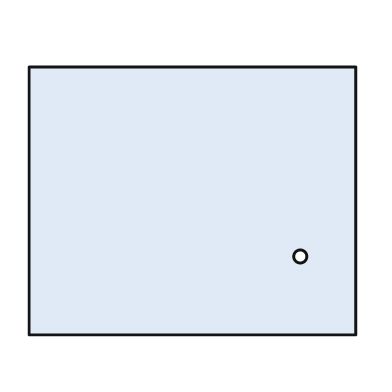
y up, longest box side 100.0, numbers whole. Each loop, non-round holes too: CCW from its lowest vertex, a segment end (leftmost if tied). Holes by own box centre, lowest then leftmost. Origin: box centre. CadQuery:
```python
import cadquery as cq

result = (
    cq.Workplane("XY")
    .moveTo(-50.0, -41.0)
    .lineTo(50.0, -41.0)
    .lineTo(50.0, 41.0)
    .lineTo(-50.0, 41.0)
    .close()
    .moveTo(33.0, -17.0)
    .circle(2.0)
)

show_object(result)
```